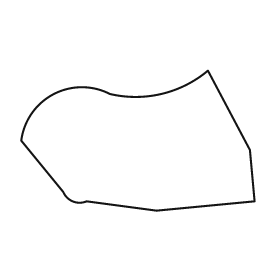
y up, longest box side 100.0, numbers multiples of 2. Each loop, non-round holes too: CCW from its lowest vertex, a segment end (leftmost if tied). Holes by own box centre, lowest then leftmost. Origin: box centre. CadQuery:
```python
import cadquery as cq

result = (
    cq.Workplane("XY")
    .moveTo(8.0, -30.0)
    .lineTo(50.0, -26.0)
    .lineTo(48.0, -4.0)
    .lineTo(30.0, 30.0)
    .threePointArc((10.0, 20.0), (-12.0, 20.0))
    .threePointArc((-36.0, 20.0), (-50.0, 0.0))
    .lineTo(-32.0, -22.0)
    .threePointArc((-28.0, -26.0), (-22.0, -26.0))
    .close()
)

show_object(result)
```